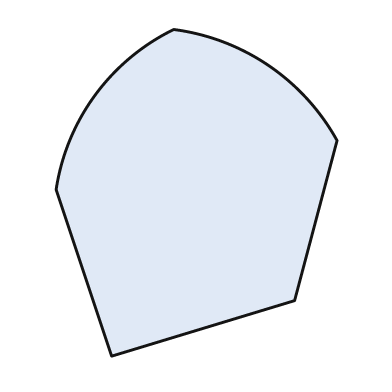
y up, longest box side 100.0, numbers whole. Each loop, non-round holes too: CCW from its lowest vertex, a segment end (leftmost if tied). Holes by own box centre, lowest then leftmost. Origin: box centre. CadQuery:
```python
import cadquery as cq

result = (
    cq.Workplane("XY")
    .moveTo(-26.0, -50.0)
    .lineTo(30.0, -33.0)
    .lineTo(43.0, 16.0)
    .threePointArc((22.0, 39.0), (-7.0, 50.0))
    .threePointArc((-31.0, 30.0), (-43.0, 1.0))
    .close()
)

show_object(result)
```